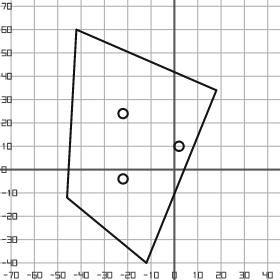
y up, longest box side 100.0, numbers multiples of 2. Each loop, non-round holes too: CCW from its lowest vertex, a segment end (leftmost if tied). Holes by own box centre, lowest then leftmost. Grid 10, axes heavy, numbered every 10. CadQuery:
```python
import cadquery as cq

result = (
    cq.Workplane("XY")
    .moveTo(-12.0, -40.0)
    .lineTo(18.0, 34.0)
    .lineTo(-42.0, 60.0)
    .lineTo(-46.0, -12.0)
    .close()
    .moveTo(-22.0, -4.0)
    .circle(2.0)
    .moveTo(2.0, 10.0)
    .circle(2.0)
    .moveTo(-22.0, 24.0)
    .circle(2.0)
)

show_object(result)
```